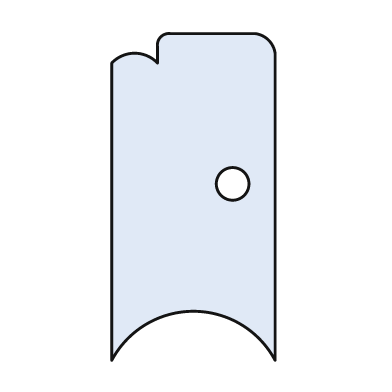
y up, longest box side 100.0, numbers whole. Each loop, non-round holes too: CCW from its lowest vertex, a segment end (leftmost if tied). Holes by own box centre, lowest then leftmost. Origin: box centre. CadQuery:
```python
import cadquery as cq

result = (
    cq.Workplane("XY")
    .moveTo(-25.0, -50.0)
    .threePointArc((0.0, -35.0), (25.0, -50.0))
    .lineTo(25.0, 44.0)
    .threePointArc((23.0, 48.0), (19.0, 50.0))
    .lineTo(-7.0, 50.0)
    .threePointArc((-10.0, 49.0), (-11.0, 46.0))
    .lineTo(-11.0, 41.0)
    .threePointArc((-18.0, 44.0), (-25.0, 41.0))
    .close()
    .moveTo(12.0, 4.0)
    .circle(5.0)
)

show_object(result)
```